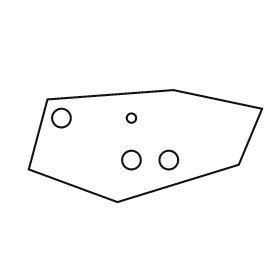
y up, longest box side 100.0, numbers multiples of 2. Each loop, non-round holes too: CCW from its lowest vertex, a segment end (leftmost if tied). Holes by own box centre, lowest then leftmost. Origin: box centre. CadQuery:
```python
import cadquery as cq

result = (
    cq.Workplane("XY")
    .moveTo(-12.0, -24.0)
    .lineTo(40.0, -8.0)
    .lineTo(50.0, 16.0)
    .lineTo(12.0, 24.0)
    .lineTo(-42.0, 20.0)
    .lineTo(-50.0, -10.0)
    .close()
    .moveTo(-6.0, -6.0)
    .circle(4.0)
    .moveTo(10.0, -6.0)
    .circle(4.0)
    .moveTo(-36.0, 12.0)
    .circle(4.0)
    .moveTo(-6.0, 12.0)
    .circle(2.0)
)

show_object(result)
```